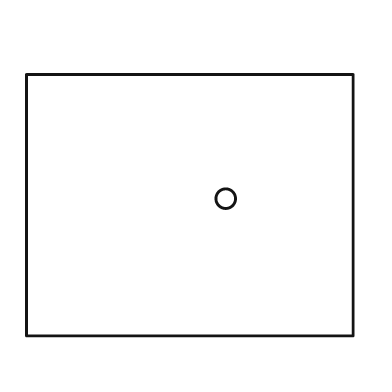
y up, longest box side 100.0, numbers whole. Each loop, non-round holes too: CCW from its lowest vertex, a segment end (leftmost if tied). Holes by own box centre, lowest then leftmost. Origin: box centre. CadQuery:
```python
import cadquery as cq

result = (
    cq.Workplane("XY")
    .moveTo(-50.0, -40.0)
    .lineTo(50.0, -40.0)
    .lineTo(50.0, 40.0)
    .lineTo(-50.0, 40.0)
    .close()
    .moveTo(11.0, 2.0)
    .circle(3.0)
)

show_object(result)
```